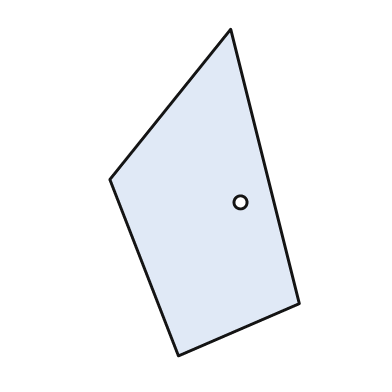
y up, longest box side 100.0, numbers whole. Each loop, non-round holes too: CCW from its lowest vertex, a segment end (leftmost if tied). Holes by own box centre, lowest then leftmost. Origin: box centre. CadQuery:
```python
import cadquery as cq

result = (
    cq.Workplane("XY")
    .moveTo(-8.0, -50.0)
    .lineTo(29.0, -34.0)
    .lineTo(8.0, 50.0)
    .lineTo(-29.0, 4.0)
    .close()
    .moveTo(11.0, -3.0)
    .circle(2.0)
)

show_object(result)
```